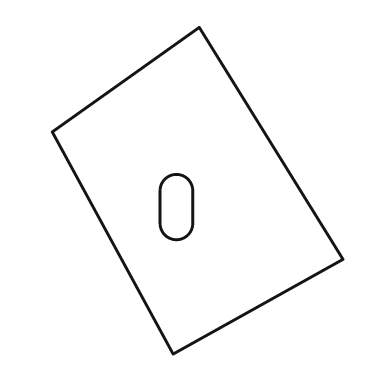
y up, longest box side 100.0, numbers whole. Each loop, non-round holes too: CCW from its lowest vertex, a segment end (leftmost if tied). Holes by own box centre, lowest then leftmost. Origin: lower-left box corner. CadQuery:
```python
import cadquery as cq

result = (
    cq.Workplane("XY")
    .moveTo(37.0, 0.0)
    .lineTo(89.0, 29.0)
    .lineTo(45.0, 100.0)
    .lineTo(0.0, 68.0)
    .close()
    .moveTo(33.0, 40.0)
    .threePointArc((38.0, 35.0), (43.0, 40.0))
    .lineTo(43.0, 50.0)
    .threePointArc((38.0, 55.0), (33.0, 50.0))
    .close()
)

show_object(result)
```